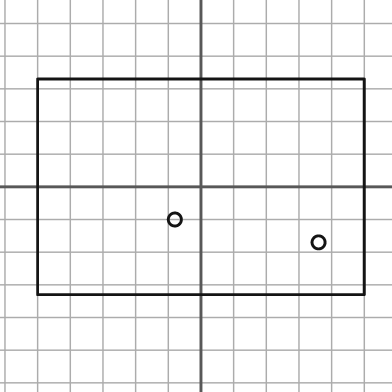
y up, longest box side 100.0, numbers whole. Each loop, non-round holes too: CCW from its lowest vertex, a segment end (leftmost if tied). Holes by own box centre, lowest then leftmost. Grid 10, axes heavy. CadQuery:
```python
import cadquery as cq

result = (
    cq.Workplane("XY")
    .moveTo(-50.0, -33.0)
    .lineTo(50.0, -33.0)
    .lineTo(50.0, 33.0)
    .lineTo(-50.0, 33.0)
    .close()
    .moveTo(36.0, -17.0)
    .circle(2.0)
    .moveTo(-8.0, -10.0)
    .circle(2.0)
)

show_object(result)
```